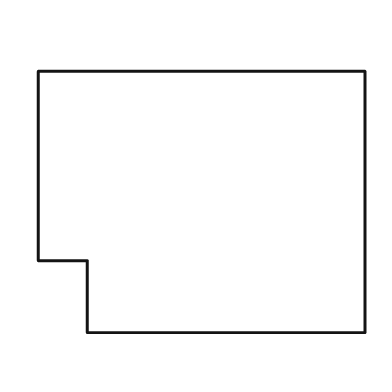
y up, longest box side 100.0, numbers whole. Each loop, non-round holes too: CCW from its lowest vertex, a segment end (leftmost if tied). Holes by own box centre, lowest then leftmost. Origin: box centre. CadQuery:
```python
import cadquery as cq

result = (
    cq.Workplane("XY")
    .moveTo(-35.0, -40.0)
    .lineTo(50.0, -40.0)
    .lineTo(50.0, 40.0)
    .lineTo(-50.0, 40.0)
    .lineTo(-50.0, -18.0)
    .lineTo(-35.0, -18.0)
    .close()
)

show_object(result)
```